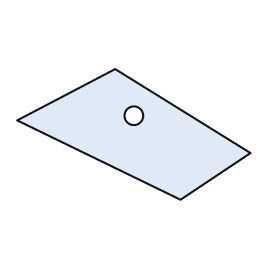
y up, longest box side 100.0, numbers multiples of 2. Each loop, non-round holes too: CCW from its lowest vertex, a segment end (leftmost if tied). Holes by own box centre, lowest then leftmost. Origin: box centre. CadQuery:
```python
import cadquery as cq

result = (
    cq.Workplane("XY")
    .moveTo(20.0, -28.0)
    .lineTo(50.0, -8.0)
    .lineTo(-8.0, 28.0)
    .lineTo(-50.0, 6.0)
    .close()
    .moveTo(0.0, 8.0)
    .circle(4.0)
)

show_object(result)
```